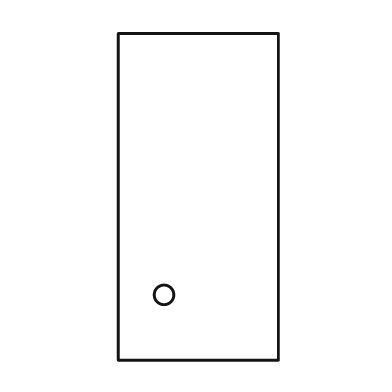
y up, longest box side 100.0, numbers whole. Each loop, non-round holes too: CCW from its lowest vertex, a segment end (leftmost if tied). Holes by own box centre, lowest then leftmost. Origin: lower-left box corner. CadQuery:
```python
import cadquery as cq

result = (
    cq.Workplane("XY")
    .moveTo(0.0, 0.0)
    .lineTo(49.0, 0.0)
    .lineTo(49.0, 100.0)
    .lineTo(0.0, 100.0)
    .close()
    .moveTo(14.0, 20.0)
    .circle(3.0)
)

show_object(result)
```